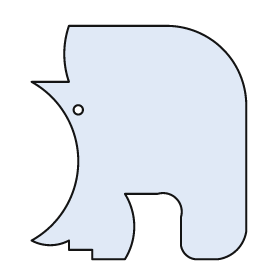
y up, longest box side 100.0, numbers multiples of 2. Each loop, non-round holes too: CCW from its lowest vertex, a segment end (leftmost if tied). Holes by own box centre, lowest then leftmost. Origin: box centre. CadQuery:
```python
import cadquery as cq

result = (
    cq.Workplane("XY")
    .moveTo(-20.0, -50.0)
    .lineTo(-6.0, -50.0)
    .threePointArc((-2.0, -36.0), (-6.0, -22.0))
    .lineTo(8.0, -22.0)
    .threePointArc((16.0, -24.0), (18.0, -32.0))
    .lineTo(18.0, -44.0)
    .threePointArc((20.0, -48.0), (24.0, -50.0))
    .lineTo(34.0, -50.0)
    .threePointArc((42.0, -46.0), (46.0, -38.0))
    .lineTo(46.0, 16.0)
    .threePointArc((36.0, 40.0), (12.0, 50.0))
    .lineTo(-30.0, 50.0)
    .threePointArc((-32.0, 38.0), (-30.0, 26.0))
    .lineTo(-46.0, 26.0)
    .threePointArc((-26.0, -8.0), (-46.0, -42.0))
    .threePointArc((-38.0, -44.0), (-30.0, -42.0))
    .lineTo(-30.0, -46.0)
    .lineTo(-20.0, -46.0)
    .close()
    .moveTo(-26.0, 14.0)
    .circle(2.0)
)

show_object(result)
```